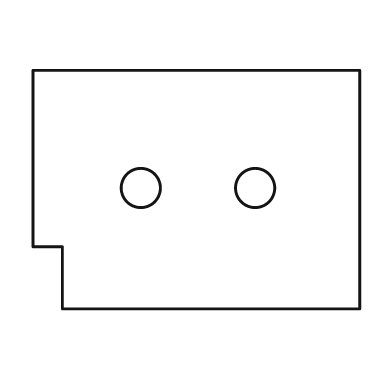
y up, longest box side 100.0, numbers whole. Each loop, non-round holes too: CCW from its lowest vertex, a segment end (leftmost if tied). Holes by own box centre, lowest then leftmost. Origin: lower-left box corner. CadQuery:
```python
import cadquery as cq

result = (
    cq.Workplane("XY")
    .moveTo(9.0, 0.0)
    .lineTo(100.0, 0.0)
    .lineTo(100.0, 73.0)
    .lineTo(0.0, 73.0)
    .lineTo(0.0, 19.0)
    .lineTo(9.0, 19.0)
    .close()
    .moveTo(33.0, 37.0)
    .circle(6.0)
    .moveTo(68.0, 37.0)
    .circle(6.0)
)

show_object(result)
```